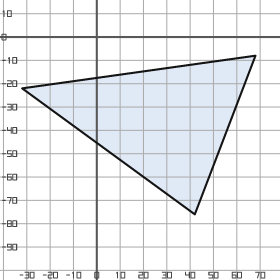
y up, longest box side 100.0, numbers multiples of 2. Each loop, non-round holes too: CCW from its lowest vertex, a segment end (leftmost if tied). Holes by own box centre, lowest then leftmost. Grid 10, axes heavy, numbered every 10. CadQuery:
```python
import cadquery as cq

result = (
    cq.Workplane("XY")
    .moveTo(42.0, -76.0)
    .lineTo(68.0, -8.0)
    .lineTo(-32.0, -22.0)
    .close()
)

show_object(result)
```